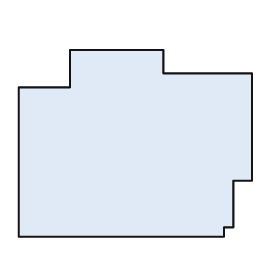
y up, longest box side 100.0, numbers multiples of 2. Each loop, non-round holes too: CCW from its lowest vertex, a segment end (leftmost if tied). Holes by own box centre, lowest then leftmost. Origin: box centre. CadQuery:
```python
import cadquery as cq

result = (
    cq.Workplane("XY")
    .moveTo(-50.0, -40.0)
    .lineTo(38.0, -40.0)
    .lineTo(38.0, -36.0)
    .lineTo(42.0, -36.0)
    .lineTo(42.0, -16.0)
    .lineTo(50.0, -16.0)
    .lineTo(50.0, 30.0)
    .lineTo(12.0, 30.0)
    .lineTo(12.0, 40.0)
    .lineTo(-28.0, 40.0)
    .lineTo(-28.0, 24.0)
    .lineTo(-50.0, 24.0)
    .close()
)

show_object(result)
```